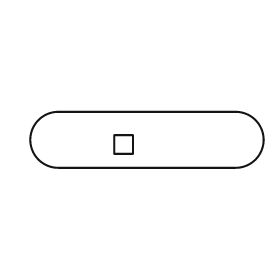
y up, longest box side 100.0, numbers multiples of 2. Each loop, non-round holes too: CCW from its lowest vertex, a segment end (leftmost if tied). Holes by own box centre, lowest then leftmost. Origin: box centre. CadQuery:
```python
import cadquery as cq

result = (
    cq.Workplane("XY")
    .moveTo(-38.0, -12.0)
    .lineTo(38.0, -12.0)
    .threePointArc((50.0, 0.0), (38.0, 12.0))
    .lineTo(-38.0, 12.0)
    .threePointArc((-50.0, 0.0), (-38.0, -12.0))
    .close()
    .moveTo(-14.0, -6.0)
    .lineTo(-6.0, -6.0)
    .lineTo(-6.0, 2.0)
    .lineTo(-14.0, 2.0)
    .close()
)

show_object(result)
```